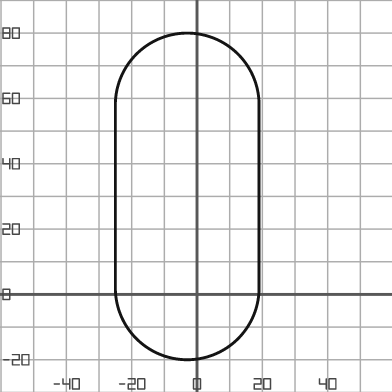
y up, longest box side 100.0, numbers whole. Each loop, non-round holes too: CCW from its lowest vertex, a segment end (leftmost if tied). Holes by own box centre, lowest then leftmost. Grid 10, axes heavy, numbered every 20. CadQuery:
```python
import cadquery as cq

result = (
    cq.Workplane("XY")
    .moveTo(-25.0, 2.0)
    .threePointArc((-3.0, -20.0), (19.0, 2.0))
    .lineTo(19.0, 58.0)
    .threePointArc((-3.0, 80.0), (-25.0, 58.0))
    .close()
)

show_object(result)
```